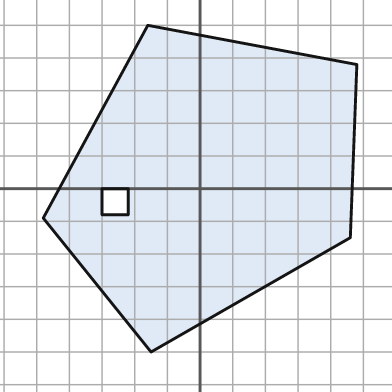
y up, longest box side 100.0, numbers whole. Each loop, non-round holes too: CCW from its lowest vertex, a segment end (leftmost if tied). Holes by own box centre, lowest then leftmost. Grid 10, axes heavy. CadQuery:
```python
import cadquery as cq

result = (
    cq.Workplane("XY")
    .moveTo(-15.0, -50.0)
    .lineTo(46.0, -15.0)
    .lineTo(48.0, 38.0)
    .lineTo(-16.0, 50.0)
    .lineTo(-48.0, -9.0)
    .close()
    .moveTo(-30.0, -8.0)
    .lineTo(-22.0, -8.0)
    .lineTo(-22.0, 0.0)
    .lineTo(-30.0, 0.0)
    .close()
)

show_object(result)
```